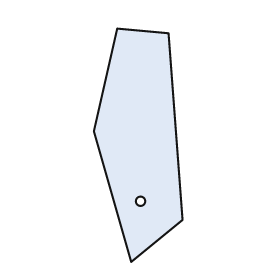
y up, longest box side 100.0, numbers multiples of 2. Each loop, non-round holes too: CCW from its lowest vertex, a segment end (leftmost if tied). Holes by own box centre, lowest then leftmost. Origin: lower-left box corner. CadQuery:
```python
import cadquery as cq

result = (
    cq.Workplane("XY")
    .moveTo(16.0, 0.0)
    .lineTo(38.0, 18.0)
    .lineTo(32.0, 98.0)
    .lineTo(10.0, 100.0)
    .lineTo(0.0, 56.0)
    .close()
    .moveTo(20.0, 26.0)
    .circle(2.0)
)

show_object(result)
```